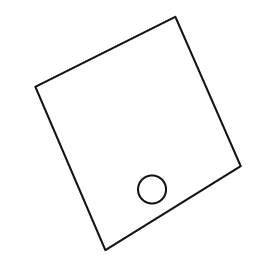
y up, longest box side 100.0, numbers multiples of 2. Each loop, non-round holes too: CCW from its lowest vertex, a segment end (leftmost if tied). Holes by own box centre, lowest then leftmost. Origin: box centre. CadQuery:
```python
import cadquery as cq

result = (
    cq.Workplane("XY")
    .moveTo(-14.0, -50.0)
    .lineTo(44.0, -14.0)
    .lineTo(16.0, 50.0)
    .lineTo(-44.0, 20.0)
    .close()
    .moveTo(6.0, -24.0)
    .circle(6.0)
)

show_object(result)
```